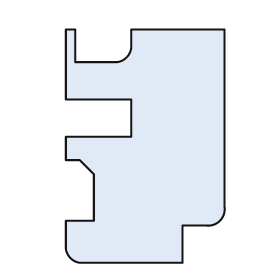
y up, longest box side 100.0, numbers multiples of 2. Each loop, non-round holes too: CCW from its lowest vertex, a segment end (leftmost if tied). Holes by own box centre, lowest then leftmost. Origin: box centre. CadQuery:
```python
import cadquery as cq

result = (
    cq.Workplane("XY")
    .moveTo(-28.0, -50.0)
    .lineTo(16.0, -50.0)
    .lineTo(16.0, -34.0)
    .lineTo(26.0, -34.0)
    .threePointArc((32.0, -32.0), (34.0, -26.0))
    .lineTo(34.0, 50.0)
    .lineTo(-6.0, 50.0)
    .lineTo(-6.0, 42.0)
    .threePointArc((-8.0, 38.0), (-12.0, 36.0))
    .lineTo(-30.0, 36.0)
    .lineTo(-30.0, 50.0)
    .lineTo(-34.0, 50.0)
    .lineTo(-34.0, 20.0)
    .lineTo(-6.0, 20.0)
    .lineTo(-6.0, 4.0)
    .lineTo(-34.0, 4.0)
    .lineTo(-34.0, -6.0)
    .lineTo(-28.0, -6.0)
    .lineTo(-22.0, -12.0)
    .lineTo(-22.0, -32.0)
    .lineTo(-34.0, -32.0)
    .lineTo(-34.0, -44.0)
    .threePointArc((-32.0, -48.0), (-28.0, -50.0))
    .close()
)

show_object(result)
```